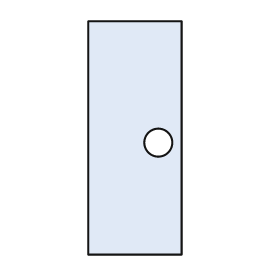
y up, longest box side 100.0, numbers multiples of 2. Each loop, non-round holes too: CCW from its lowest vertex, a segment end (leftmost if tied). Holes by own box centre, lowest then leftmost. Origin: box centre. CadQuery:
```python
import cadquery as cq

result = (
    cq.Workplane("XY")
    .moveTo(-20.0, -50.0)
    .lineTo(20.0, -50.0)
    .lineTo(20.0, 50.0)
    .lineTo(-20.0, 50.0)
    .close()
    .moveTo(10.0, -2.0)
    .circle(6.0)
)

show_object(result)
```